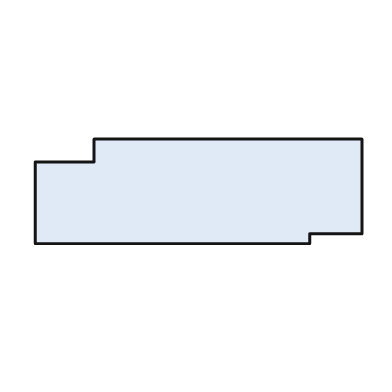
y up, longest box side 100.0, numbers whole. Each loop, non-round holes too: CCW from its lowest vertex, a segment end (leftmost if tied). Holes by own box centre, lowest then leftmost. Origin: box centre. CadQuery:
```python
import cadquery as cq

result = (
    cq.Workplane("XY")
    .moveTo(-50.0, -16.0)
    .lineTo(34.0, -16.0)
    .lineTo(34.0, -13.0)
    .lineTo(50.0, -13.0)
    .lineTo(50.0, 16.0)
    .lineTo(-32.0, 16.0)
    .lineTo(-32.0, 9.0)
    .lineTo(-50.0, 9.0)
    .close()
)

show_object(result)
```